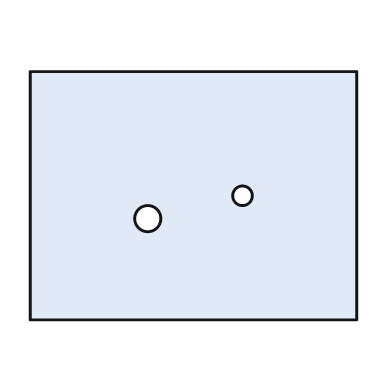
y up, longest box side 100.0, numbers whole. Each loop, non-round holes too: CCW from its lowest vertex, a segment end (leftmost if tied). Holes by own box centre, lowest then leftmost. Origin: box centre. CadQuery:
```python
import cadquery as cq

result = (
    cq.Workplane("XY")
    .moveTo(-50.0, -38.0)
    .lineTo(50.0, -38.0)
    .lineTo(50.0, 38.0)
    .lineTo(-50.0, 38.0)
    .close()
    .moveTo(-14.0, -7.0)
    .circle(4.0)
    .moveTo(15.0, 0.0)
    .circle(3.0)
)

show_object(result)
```